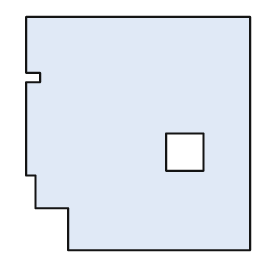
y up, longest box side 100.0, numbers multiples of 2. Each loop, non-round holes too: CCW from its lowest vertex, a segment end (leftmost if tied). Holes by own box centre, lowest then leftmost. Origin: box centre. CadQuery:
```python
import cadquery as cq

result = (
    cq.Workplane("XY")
    .moveTo(-30.0, -50.0)
    .lineTo(48.0, -50.0)
    .lineTo(48.0, 50.0)
    .lineTo(-48.0, 50.0)
    .lineTo(-48.0, 26.0)
    .lineTo(-42.0, 26.0)
    .lineTo(-42.0, 22.0)
    .lineTo(-48.0, 22.0)
    .lineTo(-48.0, -18.0)
    .lineTo(-44.0, -18.0)
    .lineTo(-44.0, -32.0)
    .lineTo(-30.0, -32.0)
    .close()
    .moveTo(12.0, -16.0)
    .lineTo(28.0, -16.0)
    .lineTo(28.0, 0.0)
    .lineTo(12.0, 0.0)
    .close()
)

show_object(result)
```